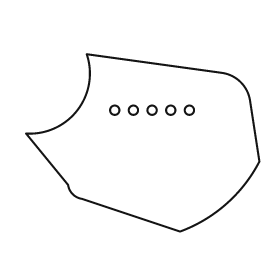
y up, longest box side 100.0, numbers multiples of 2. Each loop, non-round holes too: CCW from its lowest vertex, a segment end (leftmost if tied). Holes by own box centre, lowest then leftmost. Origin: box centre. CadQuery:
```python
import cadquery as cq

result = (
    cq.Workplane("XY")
    .moveTo(16.0, -38.0)
    .threePointArc((36.0, -26.0), (50.0, -8.0))
    .lineTo(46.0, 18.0)
    .threePointArc((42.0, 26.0), (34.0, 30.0))
    .lineTo(-24.0, 38.0)
    .threePointArc((-28.0, 14.0), (-50.0, 4.0))
    .lineTo(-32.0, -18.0)
    .threePointArc((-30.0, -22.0), (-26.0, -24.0))
    .close()
    .moveTo(-12.0, 14.0)
    .circle(2.0)
    .moveTo(-4.0, 14.0)
    .circle(2.0)
    .moveTo(4.0, 14.0)
    .circle(2.0)
    .moveTo(12.0, 14.0)
    .circle(2.0)
    .moveTo(20.0, 14.0)
    .circle(2.0)
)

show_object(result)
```